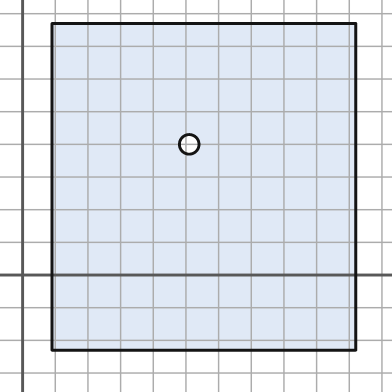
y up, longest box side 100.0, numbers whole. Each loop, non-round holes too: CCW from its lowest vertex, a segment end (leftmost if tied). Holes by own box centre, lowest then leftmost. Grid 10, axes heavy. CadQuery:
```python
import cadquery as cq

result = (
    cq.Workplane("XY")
    .moveTo(9.0, -23.0)
    .lineTo(102.0, -23.0)
    .lineTo(102.0, 77.0)
    .lineTo(9.0, 77.0)
    .close()
    .moveTo(51.0, 40.0)
    .circle(3.0)
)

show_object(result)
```